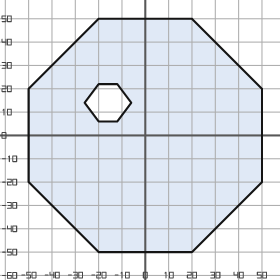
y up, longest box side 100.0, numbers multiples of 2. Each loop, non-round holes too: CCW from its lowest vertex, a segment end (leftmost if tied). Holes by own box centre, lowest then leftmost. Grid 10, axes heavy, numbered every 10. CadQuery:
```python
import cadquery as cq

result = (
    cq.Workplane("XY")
    .moveTo(-20.0, -50.0)
    .lineTo(20.0, -50.0)
    .lineTo(50.0, -20.0)
    .lineTo(50.0, 20.0)
    .lineTo(20.0, 50.0)
    .lineTo(-20.0, 50.0)
    .lineTo(-50.0, 20.0)
    .lineTo(-50.0, -20.0)
    .close()
    .moveTo(-20.0, 6.0)
    .lineTo(-12.0, 6.0)
    .lineTo(-6.0, 14.0)
    .lineTo(-12.0, 22.0)
    .lineTo(-20.0, 22.0)
    .lineTo(-26.0, 14.0)
    .close()
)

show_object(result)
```